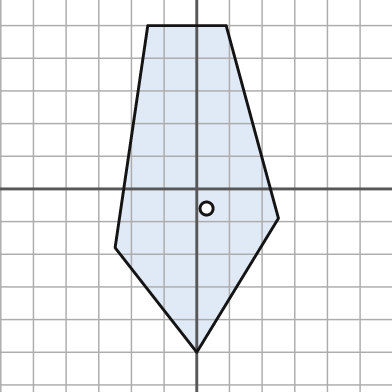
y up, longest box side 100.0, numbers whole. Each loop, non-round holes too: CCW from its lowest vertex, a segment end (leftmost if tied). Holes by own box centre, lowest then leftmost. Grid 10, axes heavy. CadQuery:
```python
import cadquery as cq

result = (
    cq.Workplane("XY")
    .moveTo(0.0, -50.0)
    .lineTo(25.0, -9.0)
    .lineTo(9.0, 50.0)
    .lineTo(-15.0, 50.0)
    .lineTo(-25.0, -18.0)
    .close()
    .moveTo(3.0, -6.0)
    .circle(2.0)
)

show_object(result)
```